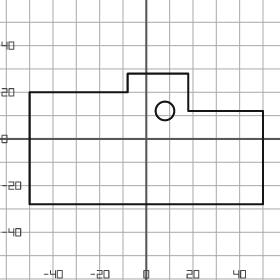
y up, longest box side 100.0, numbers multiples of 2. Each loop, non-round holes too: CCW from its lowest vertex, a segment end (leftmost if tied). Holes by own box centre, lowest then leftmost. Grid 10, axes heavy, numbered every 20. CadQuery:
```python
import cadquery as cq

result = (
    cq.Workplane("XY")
    .moveTo(-50.0, -28.0)
    .lineTo(50.0, -28.0)
    .lineTo(50.0, 12.0)
    .lineTo(18.0, 12.0)
    .lineTo(18.0, 28.0)
    .lineTo(-8.0, 28.0)
    .lineTo(-8.0, 20.0)
    .lineTo(-50.0, 20.0)
    .close()
    .moveTo(8.0, 12.0)
    .circle(4.0)
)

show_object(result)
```